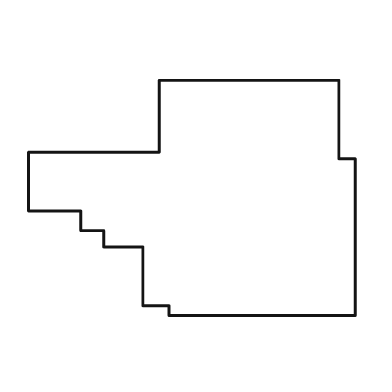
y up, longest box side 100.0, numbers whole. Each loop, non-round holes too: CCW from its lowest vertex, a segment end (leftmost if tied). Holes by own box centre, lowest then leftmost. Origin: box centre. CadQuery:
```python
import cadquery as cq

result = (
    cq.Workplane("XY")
    .moveTo(-7.0, -36.0)
    .lineTo(50.0, -36.0)
    .lineTo(50.0, 12.0)
    .lineTo(45.0, 12.0)
    .lineTo(45.0, 36.0)
    .lineTo(-10.0, 36.0)
    .lineTo(-10.0, 14.0)
    .lineTo(-50.0, 14.0)
    .lineTo(-50.0, -4.0)
    .lineTo(-34.0, -4.0)
    .lineTo(-34.0, -10.0)
    .lineTo(-27.0, -10.0)
    .lineTo(-27.0, -15.0)
    .lineTo(-15.0, -15.0)
    .lineTo(-15.0, -33.0)
    .lineTo(-7.0, -33.0)
    .close()
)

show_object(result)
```